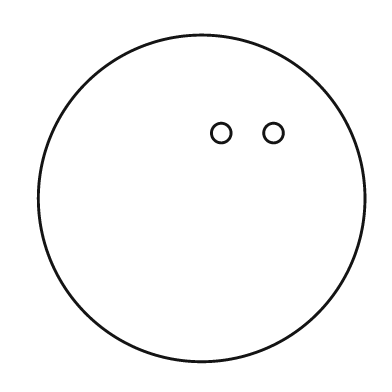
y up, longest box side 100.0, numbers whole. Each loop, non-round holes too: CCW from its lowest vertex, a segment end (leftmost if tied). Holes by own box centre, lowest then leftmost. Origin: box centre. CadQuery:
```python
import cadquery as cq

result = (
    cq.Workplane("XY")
    .moveTo(0.0, 0.0)
    .circle(50.0)
    .moveTo(6.0, 20.0)
    .circle(3.0)
    .moveTo(22.0, 20.0)
    .circle(3.0)
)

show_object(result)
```